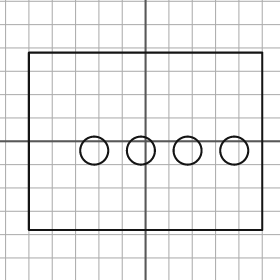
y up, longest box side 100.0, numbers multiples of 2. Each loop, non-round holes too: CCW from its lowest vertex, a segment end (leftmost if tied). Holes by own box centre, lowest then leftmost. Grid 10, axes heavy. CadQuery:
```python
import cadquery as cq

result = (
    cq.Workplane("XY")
    .moveTo(-50.0, -38.0)
    .lineTo(50.0, -38.0)
    .lineTo(50.0, 38.0)
    .lineTo(-50.0, 38.0)
    .close()
    .moveTo(-22.0, -4.0)
    .circle(6.0)
    .moveTo(-2.0, -4.0)
    .circle(6.0)
    .moveTo(18.0, -4.0)
    .circle(6.0)
    .moveTo(38.0, -4.0)
    .circle(6.0)
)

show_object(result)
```